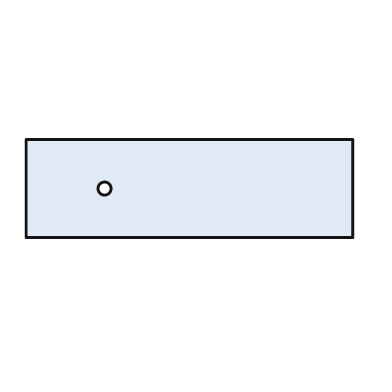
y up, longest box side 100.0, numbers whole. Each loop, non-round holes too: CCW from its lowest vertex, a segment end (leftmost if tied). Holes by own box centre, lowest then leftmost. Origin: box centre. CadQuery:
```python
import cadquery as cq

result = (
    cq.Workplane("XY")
    .moveTo(-50.0, -15.0)
    .lineTo(50.0, -15.0)
    .lineTo(50.0, 15.0)
    .lineTo(-50.0, 15.0)
    .close()
    .moveTo(-26.0, 0.0)
    .circle(2.0)
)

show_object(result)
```